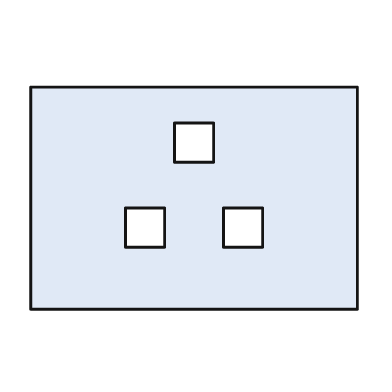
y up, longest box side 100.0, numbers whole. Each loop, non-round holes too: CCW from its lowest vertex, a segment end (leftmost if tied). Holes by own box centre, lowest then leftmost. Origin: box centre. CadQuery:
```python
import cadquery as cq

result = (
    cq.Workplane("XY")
    .moveTo(-50.0, -34.0)
    .lineTo(50.0, -34.0)
    .lineTo(50.0, 34.0)
    .lineTo(-50.0, 34.0)
    .close()
    .moveTo(-21.0, -15.0)
    .lineTo(-9.0, -15.0)
    .lineTo(-9.0, -3.0)
    .lineTo(-21.0, -3.0)
    .close()
    .moveTo(9.0, -15.0)
    .lineTo(21.0, -15.0)
    .lineTo(21.0, -3.0)
    .lineTo(9.0, -3.0)
    .close()
    .moveTo(-6.0, 11.0)
    .lineTo(6.0, 11.0)
    .lineTo(6.0, 23.0)
    .lineTo(-6.0, 23.0)
    .close()
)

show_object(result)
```